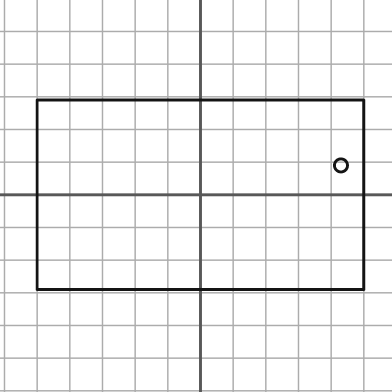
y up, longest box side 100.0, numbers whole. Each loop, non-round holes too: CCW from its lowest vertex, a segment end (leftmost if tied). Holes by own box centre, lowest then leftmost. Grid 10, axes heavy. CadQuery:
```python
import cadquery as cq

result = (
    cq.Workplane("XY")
    .moveTo(-50.0, -29.0)
    .lineTo(50.0, -29.0)
    .lineTo(50.0, 29.0)
    .lineTo(-50.0, 29.0)
    .close()
    .moveTo(43.0, 9.0)
    .circle(2.0)
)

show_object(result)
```